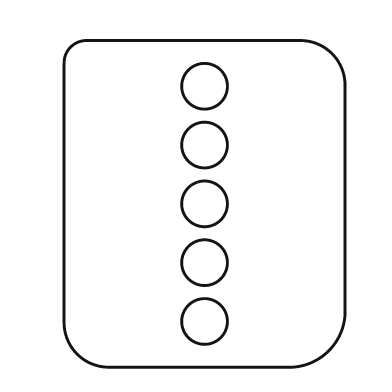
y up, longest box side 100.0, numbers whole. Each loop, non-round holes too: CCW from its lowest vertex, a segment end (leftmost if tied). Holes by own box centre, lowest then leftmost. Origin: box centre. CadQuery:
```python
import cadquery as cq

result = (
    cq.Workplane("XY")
    .moveTo(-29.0, -50.0)
    .lineTo(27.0, -50.0)
    .threePointArc((38.0, -45.0), (43.0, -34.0))
    .lineTo(43.0, 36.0)
    .threePointArc((39.0, 46.0), (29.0, 50.0))
    .lineTo(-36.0, 50.0)
    .threePointArc((-41.0, 48.0), (-43.0, 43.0))
    .lineTo(-43.0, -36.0)
    .threePointArc((-39.0, -46.0), (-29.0, -50.0))
    .close()
    .moveTo(0.0, -36.0)
    .circle(7.0)
    .moveTo(0.0, -18.0)
    .circle(7.0)
    .moveTo(0.0, 0.0)
    .circle(7.0)
    .moveTo(0.0, 18.0)
    .circle(7.0)
    .moveTo(0.0, 36.0)
    .circle(7.0)
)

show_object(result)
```